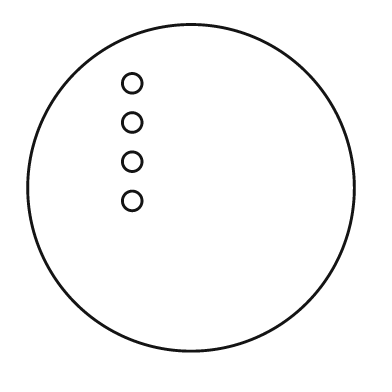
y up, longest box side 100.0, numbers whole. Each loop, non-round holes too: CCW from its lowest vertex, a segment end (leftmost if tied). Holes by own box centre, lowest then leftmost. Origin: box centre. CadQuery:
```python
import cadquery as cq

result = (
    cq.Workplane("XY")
    .moveTo(0.0, 0.0)
    .circle(50.0)
    .moveTo(-18.0, -4.0)
    .circle(3.0)
    .moveTo(-18.0, 8.0)
    .circle(3.0)
    .moveTo(-18.0, 20.0)
    .circle(3.0)
    .moveTo(-18.0, 32.0)
    .circle(3.0)
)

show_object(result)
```